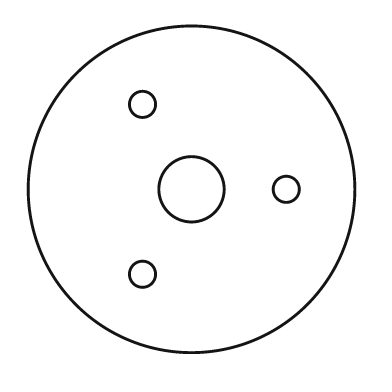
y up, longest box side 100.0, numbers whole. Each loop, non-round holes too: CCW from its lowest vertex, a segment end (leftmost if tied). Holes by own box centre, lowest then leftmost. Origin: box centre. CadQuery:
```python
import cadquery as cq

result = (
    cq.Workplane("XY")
    .moveTo(0.0, 0.0)
    .circle(50.0)
    .moveTo(-15.0, -26.0)
    .circle(4.0)
    .moveTo(0.0, 0.0)
    .circle(10.0)
    .moveTo(29.0, 0.0)
    .circle(4.0)
    .moveTo(-15.0, 26.0)
    .circle(4.0)
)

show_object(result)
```